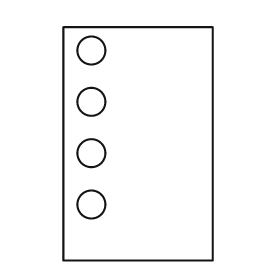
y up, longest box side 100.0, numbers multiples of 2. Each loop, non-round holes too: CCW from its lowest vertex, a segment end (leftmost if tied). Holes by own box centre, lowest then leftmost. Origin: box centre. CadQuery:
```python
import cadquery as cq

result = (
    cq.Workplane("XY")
    .moveTo(-32.0, -50.0)
    .lineTo(32.0, -50.0)
    .lineTo(32.0, 50.0)
    .lineTo(-32.0, 50.0)
    .close()
    .moveTo(-20.0, -26.0)
    .circle(6.0)
    .moveTo(-20.0, -4.0)
    .circle(6.0)
    .moveTo(-20.0, 18.0)
    .circle(6.0)
    .moveTo(-20.0, 40.0)
    .circle(6.0)
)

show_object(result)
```